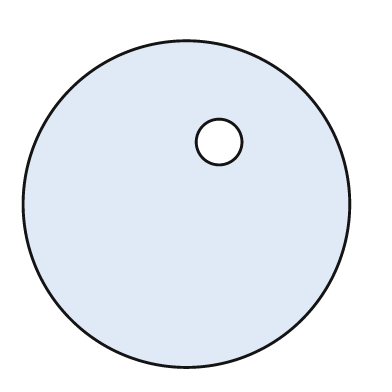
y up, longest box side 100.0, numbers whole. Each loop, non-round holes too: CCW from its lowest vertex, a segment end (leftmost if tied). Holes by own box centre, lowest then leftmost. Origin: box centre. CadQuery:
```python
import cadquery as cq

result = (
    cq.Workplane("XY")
    .moveTo(0.0, 0.0)
    .circle(50.0)
    .moveTo(10.0, 19.0)
    .circle(7.0)
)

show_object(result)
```